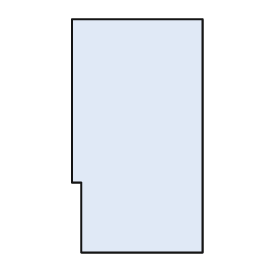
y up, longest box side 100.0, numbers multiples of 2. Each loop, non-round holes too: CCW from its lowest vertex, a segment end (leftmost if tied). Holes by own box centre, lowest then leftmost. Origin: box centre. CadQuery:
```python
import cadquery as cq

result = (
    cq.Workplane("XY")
    .moveTo(-24.0, -50.0)
    .lineTo(28.0, -50.0)
    .lineTo(28.0, 50.0)
    .lineTo(-28.0, 50.0)
    .lineTo(-28.0, -20.0)
    .lineTo(-24.0, -20.0)
    .close()
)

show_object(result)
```